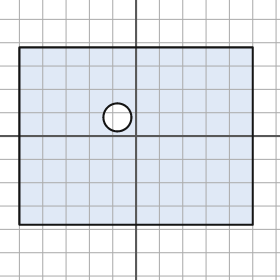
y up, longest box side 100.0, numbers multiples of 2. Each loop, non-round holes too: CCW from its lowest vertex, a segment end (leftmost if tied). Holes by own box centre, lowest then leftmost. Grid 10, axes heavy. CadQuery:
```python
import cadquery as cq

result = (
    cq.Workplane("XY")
    .moveTo(-50.0, -38.0)
    .lineTo(50.0, -38.0)
    .lineTo(50.0, 38.0)
    .lineTo(-50.0, 38.0)
    .close()
    .moveTo(-8.0, 8.0)
    .circle(6.0)
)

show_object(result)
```